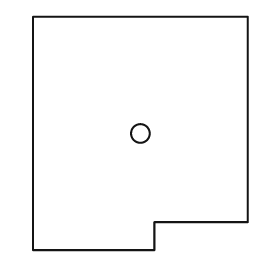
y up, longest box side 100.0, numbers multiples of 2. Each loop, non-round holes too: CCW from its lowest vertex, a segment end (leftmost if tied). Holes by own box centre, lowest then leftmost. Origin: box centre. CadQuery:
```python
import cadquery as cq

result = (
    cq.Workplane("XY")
    .moveTo(-46.0, -50.0)
    .lineTo(6.0, -50.0)
    .lineTo(6.0, -38.0)
    .lineTo(46.0, -38.0)
    .lineTo(46.0, 50.0)
    .lineTo(-46.0, 50.0)
    .close()
    .moveTo(0.0, 0.0)
    .circle(4.0)
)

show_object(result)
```